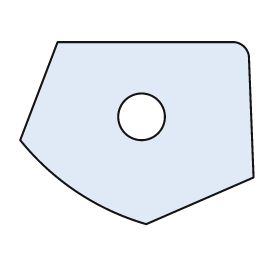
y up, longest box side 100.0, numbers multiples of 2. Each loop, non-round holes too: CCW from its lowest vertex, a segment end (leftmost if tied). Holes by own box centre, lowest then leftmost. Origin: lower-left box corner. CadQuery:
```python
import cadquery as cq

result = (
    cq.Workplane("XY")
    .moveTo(54.0, 0.0)
    .lineTo(100.0, 20.0)
    .lineTo(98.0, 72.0)
    .threePointArc((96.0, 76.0), (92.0, 78.0))
    .lineTo(16.0, 78.0)
    .lineTo(0.0, 36.0)
    .threePointArc((24.0, 14.0), (54.0, 0.0))
    .close()
    .moveTo(52.0, 46.0)
    .circle(10.0)
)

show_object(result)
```